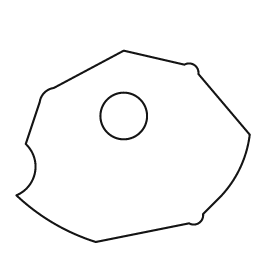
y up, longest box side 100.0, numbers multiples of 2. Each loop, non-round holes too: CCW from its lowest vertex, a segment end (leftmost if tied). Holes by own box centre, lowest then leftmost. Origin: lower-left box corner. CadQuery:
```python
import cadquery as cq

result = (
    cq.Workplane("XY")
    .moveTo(34.0, 0.0)
    .lineTo(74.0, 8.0)
    .threePointArc((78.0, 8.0), (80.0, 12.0))
    .lineTo(88.0, 20.0)
    .threePointArc((96.0, 32.0), (100.0, 46.0))
    .lineTo(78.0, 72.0)
    .threePointArc((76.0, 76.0), (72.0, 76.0))
    .lineTo(46.0, 82.0)
    .lineTo(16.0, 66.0)
    .threePointArc((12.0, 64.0), (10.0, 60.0))
    .lineTo(4.0, 42.0)
    .threePointArc((8.0, 30.0), (0.0, 20.0))
    .threePointArc((16.0, 8.0), (34.0, 0.0))
    .close()
    .moveTo(46.0, 54.0)
    .circle(10.0)
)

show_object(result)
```